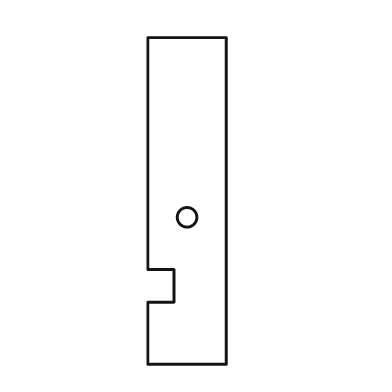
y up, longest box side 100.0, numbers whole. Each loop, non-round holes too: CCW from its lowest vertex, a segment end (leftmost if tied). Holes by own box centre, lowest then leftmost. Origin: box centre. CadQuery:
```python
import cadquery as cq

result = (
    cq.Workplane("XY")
    .moveTo(-12.0, -50.0)
    .lineTo(12.0, -50.0)
    .lineTo(12.0, 50.0)
    .lineTo(-12.0, 50.0)
    .lineTo(-12.0, -21.0)
    .lineTo(-4.0, -21.0)
    .lineTo(-4.0, -31.0)
    .lineTo(-12.0, -31.0)
    .close()
    .moveTo(0.0, -5.0)
    .circle(3.0)
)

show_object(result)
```